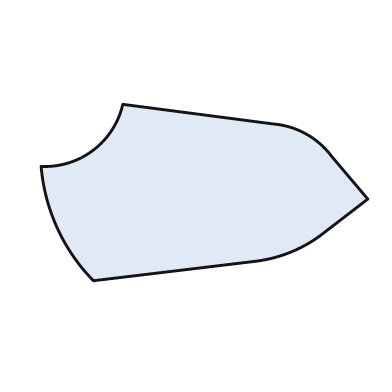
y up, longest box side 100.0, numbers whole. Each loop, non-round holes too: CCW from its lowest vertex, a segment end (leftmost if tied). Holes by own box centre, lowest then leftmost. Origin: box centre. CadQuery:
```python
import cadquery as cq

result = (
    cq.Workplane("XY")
    .moveTo(-34.0, -27.0)
    .lineTo(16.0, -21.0)
    .threePointArc((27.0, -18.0), (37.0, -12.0))
    .lineTo(50.0, -2.0)
    .lineTo(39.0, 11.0)
    .threePointArc((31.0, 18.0), (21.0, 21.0))
    .lineTo(-25.0, 27.0)
    .threePointArc((-34.0, 13.0), (-50.0, 8.0))
    .threePointArc((-45.0, -11.0), (-34.0, -27.0))
    .close()
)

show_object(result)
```